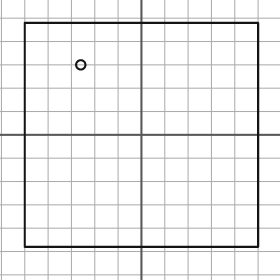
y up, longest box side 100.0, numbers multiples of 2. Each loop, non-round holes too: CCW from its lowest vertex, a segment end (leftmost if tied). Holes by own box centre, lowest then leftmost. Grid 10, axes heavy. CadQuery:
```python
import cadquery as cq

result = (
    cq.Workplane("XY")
    .moveTo(-50.0, -48.0)
    .lineTo(50.0, -48.0)
    .lineTo(50.0, 48.0)
    .lineTo(-50.0, 48.0)
    .close()
    .moveTo(-26.0, 30.0)
    .circle(2.0)
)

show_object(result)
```